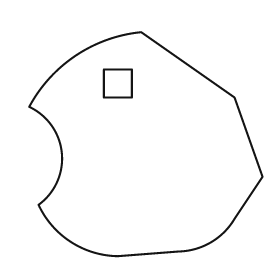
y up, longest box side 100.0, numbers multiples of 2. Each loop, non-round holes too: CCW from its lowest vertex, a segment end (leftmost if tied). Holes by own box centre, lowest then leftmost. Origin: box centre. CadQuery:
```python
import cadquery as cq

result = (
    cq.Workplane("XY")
    .moveTo(-12.0, -48.0)
    .lineTo(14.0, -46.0)
    .threePointArc((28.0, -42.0), (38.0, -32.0))
    .lineTo(50.0, -14.0)
    .lineTo(38.0, 20.0)
    .lineTo(-2.0, 48.0)
    .threePointArc((-30.0, 38.0), (-50.0, 16.0))
    .threePointArc((-36.0, -4.0), (-46.0, -26.0))
    .threePointArc((-32.0, -42.0), (-12.0, -48.0))
    .close()
    .moveTo(-18.0, 20.0)
    .lineTo(-6.0, 20.0)
    .lineTo(-6.0, 32.0)
    .lineTo(-18.0, 32.0)
    .close()
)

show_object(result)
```